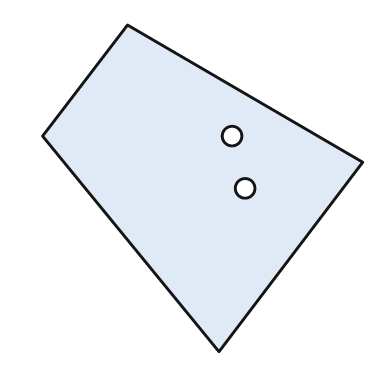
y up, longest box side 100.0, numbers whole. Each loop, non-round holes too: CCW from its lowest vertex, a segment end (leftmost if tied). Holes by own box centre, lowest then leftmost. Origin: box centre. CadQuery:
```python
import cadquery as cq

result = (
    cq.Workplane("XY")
    .moveTo(5.0, -50.0)
    .lineTo(49.0, 8.0)
    .lineTo(-23.0, 50.0)
    .lineTo(-49.0, 16.0)
    .close()
    .moveTo(13.0, 0.0)
    .circle(3.0)
    .moveTo(9.0, 16.0)
    .circle(3.0)
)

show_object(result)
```